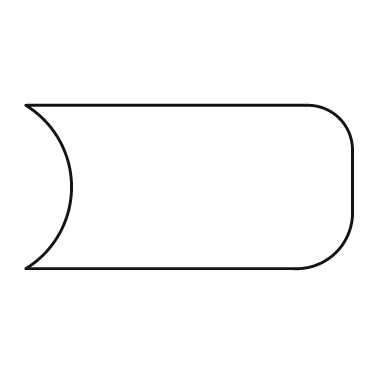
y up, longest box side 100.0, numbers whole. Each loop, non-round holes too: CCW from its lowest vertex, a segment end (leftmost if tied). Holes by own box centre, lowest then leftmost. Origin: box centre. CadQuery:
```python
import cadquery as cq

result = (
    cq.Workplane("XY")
    .moveTo(-50.0, -25.0)
    .lineTo(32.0, -25.0)
    .threePointArc((45.0, -20.0), (50.0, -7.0))
    .lineTo(50.0, 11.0)
    .threePointArc((46.0, 21.0), (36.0, 25.0))
    .lineTo(-50.0, 25.0)
    .threePointArc((-36.0, 0.0), (-50.0, -25.0))
    .close()
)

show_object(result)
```